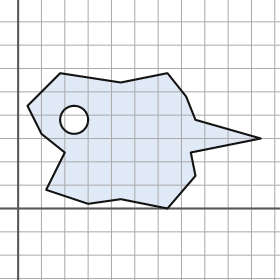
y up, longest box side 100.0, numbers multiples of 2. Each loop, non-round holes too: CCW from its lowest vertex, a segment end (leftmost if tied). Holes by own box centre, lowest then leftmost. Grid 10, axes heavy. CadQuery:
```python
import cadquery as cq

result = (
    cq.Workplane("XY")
    .moveTo(64.0, 0.0)
    .lineTo(76.0, 14.0)
    .lineTo(74.0, 24.0)
    .lineTo(104.0, 30.0)
    .lineTo(76.0, 38.0)
    .lineTo(72.0, 48.0)
    .lineTo(64.0, 58.0)
    .lineTo(44.0, 54.0)
    .lineTo(18.0, 58.0)
    .lineTo(4.0, 44.0)
    .lineTo(10.0, 32.0)
    .lineTo(20.0, 24.0)
    .lineTo(12.0, 8.0)
    .lineTo(30.0, 2.0)
    .lineTo(44.0, 4.0)
    .close()
    .moveTo(24.0, 38.0)
    .circle(6.0)
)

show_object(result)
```